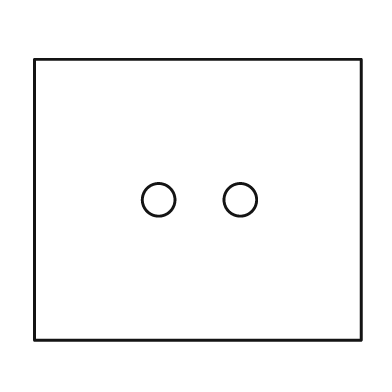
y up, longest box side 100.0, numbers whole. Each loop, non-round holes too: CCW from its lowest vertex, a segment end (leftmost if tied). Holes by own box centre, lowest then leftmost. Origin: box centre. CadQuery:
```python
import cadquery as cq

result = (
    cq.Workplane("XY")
    .moveTo(-50.0, -43.0)
    .lineTo(50.0, -43.0)
    .lineTo(50.0, 43.0)
    .lineTo(-50.0, 43.0)
    .close()
    .moveTo(-12.0, 0.0)
    .circle(5.0)
    .moveTo(13.0, 0.0)
    .circle(5.0)
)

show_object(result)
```